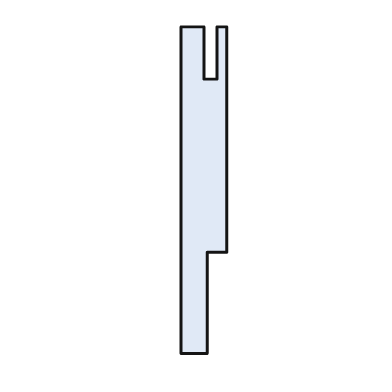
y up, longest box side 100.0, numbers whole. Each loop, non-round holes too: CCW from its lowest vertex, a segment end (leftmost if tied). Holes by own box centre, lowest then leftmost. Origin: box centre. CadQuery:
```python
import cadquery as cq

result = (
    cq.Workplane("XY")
    .moveTo(-7.0, -50.0)
    .lineTo(1.0, -50.0)
    .lineTo(1.0, -19.0)
    .lineTo(7.0, -19.0)
    .lineTo(7.0, 50.0)
    .lineTo(4.0, 50.0)
    .lineTo(4.0, 34.0)
    .lineTo(0.0, 34.0)
    .lineTo(0.0, 50.0)
    .lineTo(-7.0, 50.0)
    .close()
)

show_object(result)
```